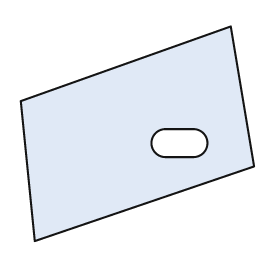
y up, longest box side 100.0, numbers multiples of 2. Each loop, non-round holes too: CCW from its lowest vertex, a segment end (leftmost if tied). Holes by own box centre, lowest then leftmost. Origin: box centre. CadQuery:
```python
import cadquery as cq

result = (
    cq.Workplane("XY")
    .moveTo(-44.0, -46.0)
    .lineTo(50.0, -14.0)
    .lineTo(40.0, 46.0)
    .lineTo(-50.0, 14.0)
    .close()
    .moveTo(12.0, -10.0)
    .lineTo(24.0, -10.0)
    .threePointArc((30.0, -4.0), (24.0, 2.0))
    .lineTo(12.0, 2.0)
    .threePointArc((6.0, -4.0), (12.0, -10.0))
    .close()
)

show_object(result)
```